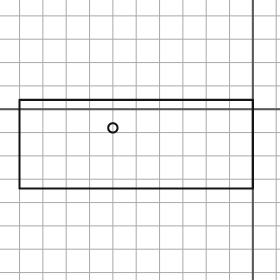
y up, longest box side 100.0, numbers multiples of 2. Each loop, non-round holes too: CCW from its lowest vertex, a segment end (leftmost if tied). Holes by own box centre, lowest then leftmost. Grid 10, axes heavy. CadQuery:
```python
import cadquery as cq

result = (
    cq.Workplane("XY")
    .moveTo(-100.0, -34.0)
    .lineTo(0.0, -34.0)
    .lineTo(0.0, 4.0)
    .lineTo(-100.0, 4.0)
    .close()
    .moveTo(-60.0, -8.0)
    .circle(2.0)
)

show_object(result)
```